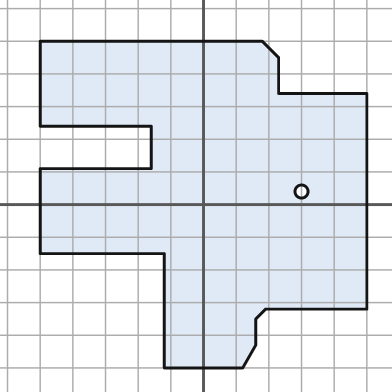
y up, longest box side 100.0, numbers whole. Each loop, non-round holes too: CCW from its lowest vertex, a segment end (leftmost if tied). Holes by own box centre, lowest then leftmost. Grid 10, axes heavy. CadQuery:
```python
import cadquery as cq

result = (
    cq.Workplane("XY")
    .moveTo(-12.0, -50.0)
    .lineTo(12.0, -50.0)
    .lineTo(16.0, -43.0)
    .lineTo(16.0, -35.0)
    .lineTo(19.0, -32.0)
    .lineTo(50.0, -32.0)
    .lineTo(50.0, 34.0)
    .lineTo(23.0, 34.0)
    .lineTo(23.0, 45.0)
    .lineTo(18.0, 50.0)
    .lineTo(-50.0, 50.0)
    .lineTo(-50.0, 24.0)
    .lineTo(-16.0, 24.0)
    .lineTo(-16.0, 11.0)
    .lineTo(-50.0, 11.0)
    .lineTo(-50.0, -15.0)
    .lineTo(-12.0, -15.0)
    .close()
    .moveTo(30.0, 4.0)
    .circle(2.0)
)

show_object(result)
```